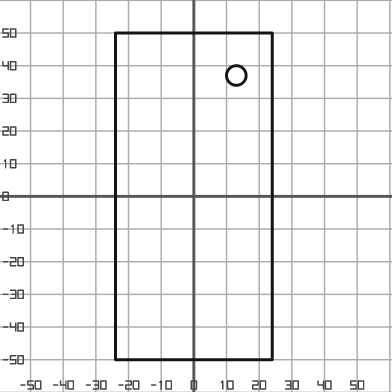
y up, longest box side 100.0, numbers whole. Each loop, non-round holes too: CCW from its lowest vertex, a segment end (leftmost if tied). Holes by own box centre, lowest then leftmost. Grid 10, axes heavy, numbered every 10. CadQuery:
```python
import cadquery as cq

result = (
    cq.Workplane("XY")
    .moveTo(-24.0, -50.0)
    .lineTo(24.0, -50.0)
    .lineTo(24.0, 50.0)
    .lineTo(-24.0, 50.0)
    .close()
    .moveTo(13.0, 37.0)
    .circle(3.0)
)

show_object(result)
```